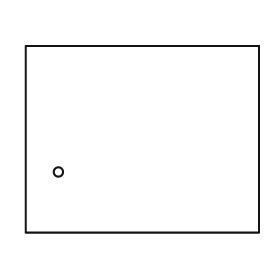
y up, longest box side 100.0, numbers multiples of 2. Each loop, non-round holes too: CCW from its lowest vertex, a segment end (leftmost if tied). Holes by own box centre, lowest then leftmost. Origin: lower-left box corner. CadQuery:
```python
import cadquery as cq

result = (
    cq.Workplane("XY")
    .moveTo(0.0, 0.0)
    .lineTo(100.0, 0.0)
    .lineTo(100.0, 80.0)
    .lineTo(0.0, 80.0)
    .close()
    .moveTo(14.0, 26.0)
    .circle(2.0)
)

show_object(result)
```